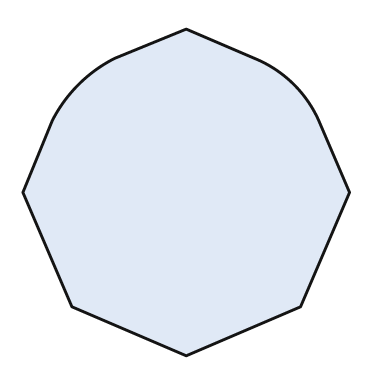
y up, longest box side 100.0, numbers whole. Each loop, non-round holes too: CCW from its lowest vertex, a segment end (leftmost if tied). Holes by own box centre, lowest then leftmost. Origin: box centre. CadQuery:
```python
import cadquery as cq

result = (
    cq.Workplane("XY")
    .moveTo(0.0, -50.0)
    .lineTo(35.0, -35.0)
    .lineTo(50.0, 0.0)
    .lineTo(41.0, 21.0)
    .threePointArc((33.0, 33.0), (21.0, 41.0))
    .lineTo(0.0, 50.0)
    .lineTo(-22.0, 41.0)
    .threePointArc((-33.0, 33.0), (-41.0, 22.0))
    .lineTo(-50.0, 0.0)
    .lineTo(-35.0, -35.0)
    .close()
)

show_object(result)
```